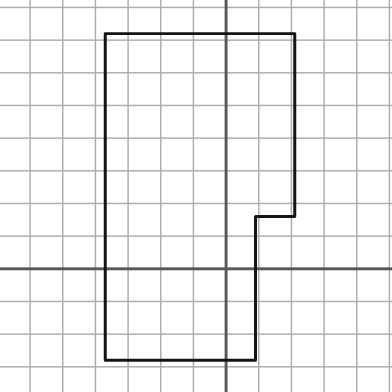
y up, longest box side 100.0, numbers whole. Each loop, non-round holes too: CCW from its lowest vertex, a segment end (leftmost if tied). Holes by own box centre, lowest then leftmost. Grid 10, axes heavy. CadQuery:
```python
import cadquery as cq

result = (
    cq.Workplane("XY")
    .moveTo(-37.0, -28.0)
    .lineTo(9.0, -28.0)
    .lineTo(9.0, 16.0)
    .lineTo(21.0, 16.0)
    .lineTo(21.0, 72.0)
    .lineTo(-37.0, 72.0)
    .close()
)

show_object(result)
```